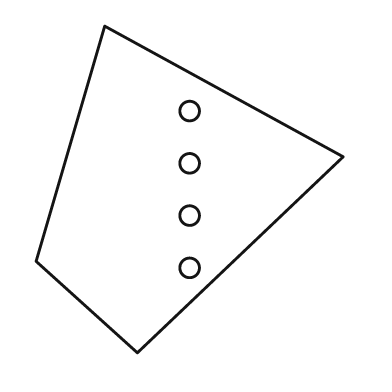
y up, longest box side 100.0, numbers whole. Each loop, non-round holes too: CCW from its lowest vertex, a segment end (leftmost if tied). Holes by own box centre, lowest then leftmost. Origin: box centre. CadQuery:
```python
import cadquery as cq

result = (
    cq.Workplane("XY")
    .moveTo(-16.0, -50.0)
    .lineTo(47.0, 10.0)
    .lineTo(-26.0, 50.0)
    .lineTo(-47.0, -22.0)
    .close()
    .moveTo(0.0, -24.0)
    .circle(3.0)
    .moveTo(0.0, -8.0)
    .circle(3.0)
    .moveTo(0.0, 8.0)
    .circle(3.0)
    .moveTo(0.0, 24.0)
    .circle(3.0)
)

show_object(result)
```